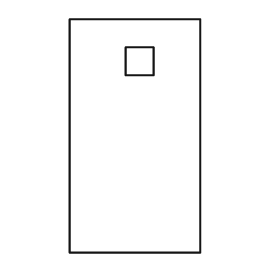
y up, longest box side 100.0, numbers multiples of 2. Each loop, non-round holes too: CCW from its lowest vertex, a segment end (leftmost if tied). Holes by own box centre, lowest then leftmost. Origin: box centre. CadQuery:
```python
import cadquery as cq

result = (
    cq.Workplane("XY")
    .moveTo(-28.0, -50.0)
    .lineTo(28.0, -50.0)
    .lineTo(28.0, 50.0)
    .lineTo(-28.0, 50.0)
    .close()
    .moveTo(-4.0, 26.0)
    .lineTo(8.0, 26.0)
    .lineTo(8.0, 38.0)
    .lineTo(-4.0, 38.0)
    .close()
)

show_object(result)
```